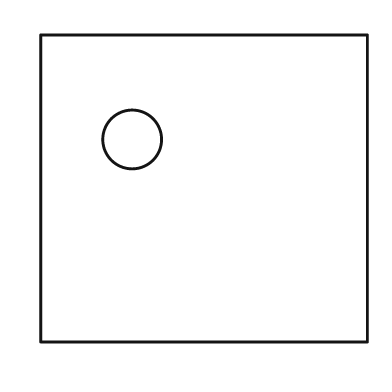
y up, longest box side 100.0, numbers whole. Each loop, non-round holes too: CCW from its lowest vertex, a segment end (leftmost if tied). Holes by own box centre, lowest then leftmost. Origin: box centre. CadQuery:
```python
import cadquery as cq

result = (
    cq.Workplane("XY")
    .moveTo(-50.0, -47.0)
    .lineTo(50.0, -47.0)
    .lineTo(50.0, 47.0)
    .lineTo(-50.0, 47.0)
    .close()
    .moveTo(-22.0, 15.0)
    .circle(9.0)
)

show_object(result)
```